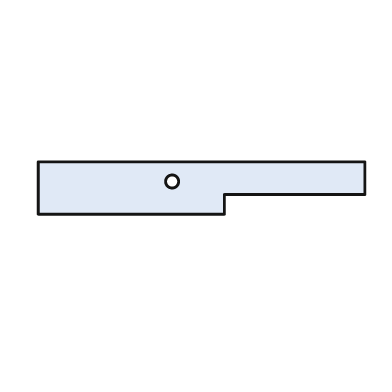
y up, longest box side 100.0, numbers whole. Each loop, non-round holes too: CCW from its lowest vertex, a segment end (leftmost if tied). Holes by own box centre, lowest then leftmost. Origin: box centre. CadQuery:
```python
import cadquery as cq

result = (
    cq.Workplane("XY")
    .moveTo(-50.0, -8.0)
    .lineTo(7.0, -8.0)
    .lineTo(7.0, -2.0)
    .lineTo(50.0, -2.0)
    .lineTo(50.0, 8.0)
    .lineTo(-50.0, 8.0)
    .close()
    .moveTo(-9.0, 2.0)
    .circle(2.0)
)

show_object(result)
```